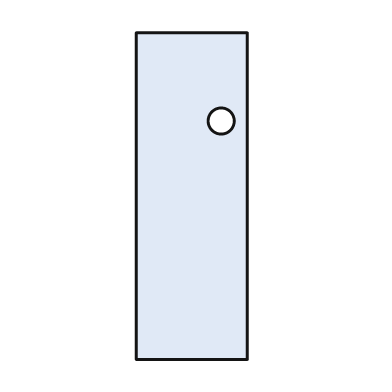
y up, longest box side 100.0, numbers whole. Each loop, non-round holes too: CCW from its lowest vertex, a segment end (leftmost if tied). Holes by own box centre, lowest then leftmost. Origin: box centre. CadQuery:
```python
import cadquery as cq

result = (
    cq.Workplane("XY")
    .moveTo(-17.0, -50.0)
    .lineTo(17.0, -50.0)
    .lineTo(17.0, 50.0)
    .lineTo(-17.0, 50.0)
    .close()
    .moveTo(9.0, 23.0)
    .circle(4.0)
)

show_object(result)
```